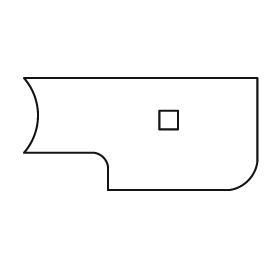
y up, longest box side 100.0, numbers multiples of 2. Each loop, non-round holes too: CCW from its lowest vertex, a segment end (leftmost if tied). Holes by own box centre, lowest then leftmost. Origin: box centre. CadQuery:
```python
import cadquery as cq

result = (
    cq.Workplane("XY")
    .moveTo(-14.0, -24.0)
    .lineTo(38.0, -24.0)
    .threePointArc((46.0, -20.0), (50.0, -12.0))
    .lineTo(50.0, 24.0)
    .lineTo(-50.0, 24.0)
    .threePointArc((-44.0, 8.0), (-50.0, -8.0))
    .lineTo(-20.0, -8.0)
    .threePointArc((-16.0, -10.0), (-14.0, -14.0))
    .close()
    .moveTo(8.0, 2.0)
    .lineTo(16.0, 2.0)
    .lineTo(16.0, 10.0)
    .lineTo(8.0, 10.0)
    .close()
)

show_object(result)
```